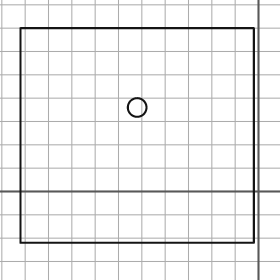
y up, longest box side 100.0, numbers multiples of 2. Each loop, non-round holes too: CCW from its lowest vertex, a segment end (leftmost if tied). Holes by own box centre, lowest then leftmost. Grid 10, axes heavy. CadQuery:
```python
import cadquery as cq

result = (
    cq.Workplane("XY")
    .moveTo(-102.0, -22.0)
    .lineTo(-2.0, -22.0)
    .lineTo(-2.0, 70.0)
    .lineTo(-102.0, 70.0)
    .close()
    .moveTo(-52.0, 36.0)
    .circle(4.0)
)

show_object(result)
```